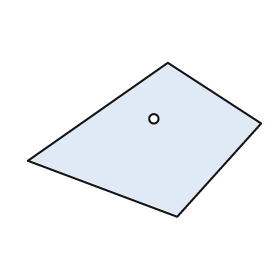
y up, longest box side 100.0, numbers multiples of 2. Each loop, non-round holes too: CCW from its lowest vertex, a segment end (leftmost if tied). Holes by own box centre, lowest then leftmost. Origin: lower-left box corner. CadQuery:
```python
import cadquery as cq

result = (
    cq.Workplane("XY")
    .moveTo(64.0, 0.0)
    .lineTo(100.0, 40.0)
    .lineTo(60.0, 66.0)
    .lineTo(0.0, 24.0)
    .close()
    .moveTo(54.0, 42.0)
    .circle(2.0)
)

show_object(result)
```